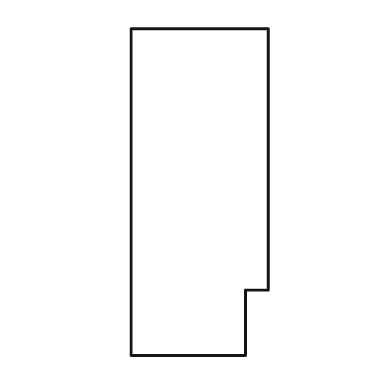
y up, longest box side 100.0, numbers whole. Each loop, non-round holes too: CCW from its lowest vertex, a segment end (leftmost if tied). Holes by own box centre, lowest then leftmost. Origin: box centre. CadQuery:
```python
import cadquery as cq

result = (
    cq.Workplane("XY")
    .moveTo(-21.0, -50.0)
    .lineTo(14.0, -50.0)
    .lineTo(14.0, -30.0)
    .lineTo(21.0, -30.0)
    .lineTo(21.0, 50.0)
    .lineTo(-21.0, 50.0)
    .close()
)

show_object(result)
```